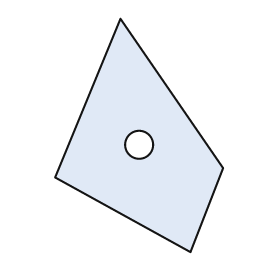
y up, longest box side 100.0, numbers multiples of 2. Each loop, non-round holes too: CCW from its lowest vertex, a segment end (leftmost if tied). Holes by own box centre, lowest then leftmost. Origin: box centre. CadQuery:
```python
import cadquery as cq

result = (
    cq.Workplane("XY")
    .moveTo(22.0, -50.0)
    .lineTo(36.0, -14.0)
    .lineTo(-8.0, 50.0)
    .lineTo(-36.0, -18.0)
    .close()
    .moveTo(0.0, -4.0)
    .circle(6.0)
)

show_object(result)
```